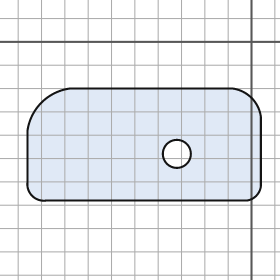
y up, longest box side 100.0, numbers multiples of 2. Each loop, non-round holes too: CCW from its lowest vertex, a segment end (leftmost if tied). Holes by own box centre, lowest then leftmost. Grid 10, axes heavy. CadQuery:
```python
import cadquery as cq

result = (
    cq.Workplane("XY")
    .moveTo(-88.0, -68.0)
    .lineTo(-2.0, -68.0)
    .threePointArc((2.0, -66.0), (4.0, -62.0))
    .lineTo(4.0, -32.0)
    .threePointArc((0.0, -24.0), (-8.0, -20.0))
    .lineTo(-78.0, -20.0)
    .threePointArc((-90.0, -26.0), (-96.0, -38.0))
    .lineTo(-96.0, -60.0)
    .threePointArc((-94.0, -66.0), (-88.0, -68.0))
    .close()
    .moveTo(-32.0, -48.0)
    .circle(6.0)
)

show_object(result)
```